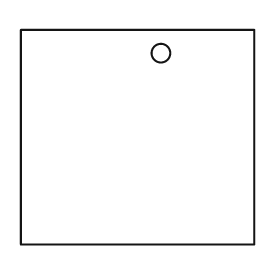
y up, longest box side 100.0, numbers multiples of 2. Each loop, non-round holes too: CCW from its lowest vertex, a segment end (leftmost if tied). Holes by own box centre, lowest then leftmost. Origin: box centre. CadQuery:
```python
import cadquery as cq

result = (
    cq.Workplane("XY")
    .moveTo(-50.0, -46.0)
    .lineTo(50.0, -46.0)
    .lineTo(50.0, 46.0)
    .lineTo(-50.0, 46.0)
    .close()
    .moveTo(10.0, 36.0)
    .circle(4.0)
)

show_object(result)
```